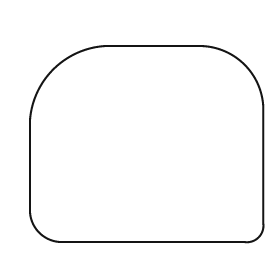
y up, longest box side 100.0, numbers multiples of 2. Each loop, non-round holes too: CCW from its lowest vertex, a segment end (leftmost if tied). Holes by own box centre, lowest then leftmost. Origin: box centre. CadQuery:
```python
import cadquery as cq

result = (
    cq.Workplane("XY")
    .moveTo(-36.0, -42.0)
    .lineTo(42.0, -42.0)
    .threePointArc((48.0, -40.0), (50.0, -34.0))
    .lineTo(50.0, 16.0)
    .threePointArc((42.0, 34.0), (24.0, 42.0))
    .lineTo(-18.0, 42.0)
    .threePointArc((-40.0, 32.0), (-50.0, 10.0))
    .lineTo(-50.0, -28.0)
    .threePointArc((-46.0, -38.0), (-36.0, -42.0))
    .close()
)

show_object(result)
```